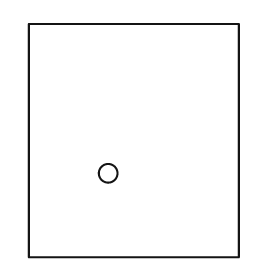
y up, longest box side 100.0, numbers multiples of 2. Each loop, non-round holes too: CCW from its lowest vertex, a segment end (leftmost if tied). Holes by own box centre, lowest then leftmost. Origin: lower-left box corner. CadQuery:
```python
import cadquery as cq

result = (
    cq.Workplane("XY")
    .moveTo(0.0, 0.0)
    .lineTo(90.0, 0.0)
    .lineTo(90.0, 100.0)
    .lineTo(0.0, 100.0)
    .close()
    .moveTo(34.0, 36.0)
    .circle(4.0)
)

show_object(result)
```